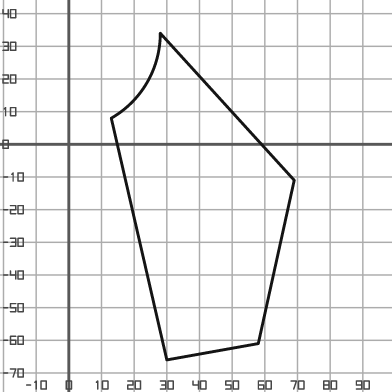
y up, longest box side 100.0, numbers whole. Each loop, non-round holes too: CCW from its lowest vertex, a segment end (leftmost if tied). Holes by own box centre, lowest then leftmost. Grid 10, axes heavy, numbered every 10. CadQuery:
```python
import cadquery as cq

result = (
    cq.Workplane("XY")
    .moveTo(30.0, -66.0)
    .lineTo(58.0, -61.0)
    .lineTo(69.0, -11.0)
    .lineTo(28.0, 34.0)
    .threePointArc((24.0, 19.0), (13.0, 8.0))
    .close()
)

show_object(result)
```